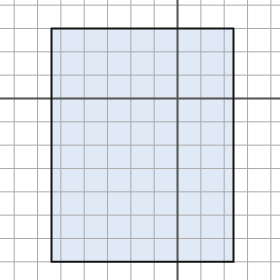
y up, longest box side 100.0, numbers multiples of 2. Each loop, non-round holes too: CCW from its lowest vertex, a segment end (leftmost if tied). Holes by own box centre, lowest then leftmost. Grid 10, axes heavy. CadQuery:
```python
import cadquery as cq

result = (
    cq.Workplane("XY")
    .moveTo(-54.0, -70.0)
    .lineTo(24.0, -70.0)
    .lineTo(24.0, 30.0)
    .lineTo(-54.0, 30.0)
    .close()
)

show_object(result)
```